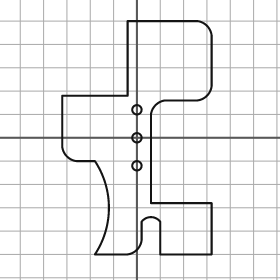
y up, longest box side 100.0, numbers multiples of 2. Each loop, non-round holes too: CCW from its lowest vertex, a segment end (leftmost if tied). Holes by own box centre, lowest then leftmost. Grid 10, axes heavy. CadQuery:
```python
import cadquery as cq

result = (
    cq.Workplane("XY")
    .moveTo(-18.0, -50.0)
    .lineTo(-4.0, -50.0)
    .threePointArc((0.0, -48.0), (2.0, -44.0))
    .lineTo(2.0, -36.0)
    .threePointArc((6.0, -34.0), (10.0, -36.0))
    .lineTo(10.0, -50.0)
    .lineTo(32.0, -50.0)
    .lineTo(32.0, -28.0)
    .lineTo(6.0, -28.0)
    .lineTo(6.0, 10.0)
    .threePointArc((8.0, 14.0), (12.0, 16.0))
    .lineTo(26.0, 16.0)
    .threePointArc((30.0, 18.0), (32.0, 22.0))
    .lineTo(32.0, 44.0)
    .threePointArc((30.0, 48.0), (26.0, 50.0))
    .lineTo(-4.0, 50.0)
    .lineTo(-4.0, 18.0)
    .lineTo(-32.0, 18.0)
    .lineTo(-32.0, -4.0)
    .threePointArc((-30.0, -8.0), (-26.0, -10.0))
    .lineTo(-18.0, -10.0)
    .threePointArc((-12.0, -30.0), (-18.0, -50.0))
    .close()
    .moveTo(0.0, -12.0)
    .circle(2.0)
    .moveTo(0.0, 0.0)
    .circle(2.0)
    .moveTo(0.0, 12.0)
    .circle(2.0)
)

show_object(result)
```